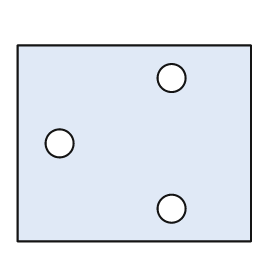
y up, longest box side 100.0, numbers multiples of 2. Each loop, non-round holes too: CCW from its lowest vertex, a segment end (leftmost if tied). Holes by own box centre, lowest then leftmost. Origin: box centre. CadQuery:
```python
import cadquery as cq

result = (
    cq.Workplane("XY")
    .moveTo(-50.0, -42.0)
    .lineTo(50.0, -42.0)
    .lineTo(50.0, 42.0)
    .lineTo(-50.0, 42.0)
    .close()
    .moveTo(16.0, -28.0)
    .circle(6.0)
    .moveTo(-32.0, 0.0)
    .circle(6.0)
    .moveTo(16.0, 28.0)
    .circle(6.0)
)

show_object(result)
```